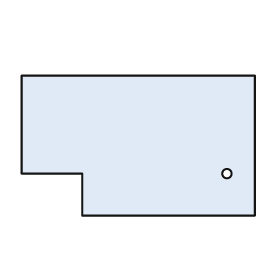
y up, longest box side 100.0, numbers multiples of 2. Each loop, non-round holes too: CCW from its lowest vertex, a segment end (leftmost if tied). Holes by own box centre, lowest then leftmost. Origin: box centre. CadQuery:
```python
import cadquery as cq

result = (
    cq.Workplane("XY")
    .moveTo(-24.0, -30.0)
    .lineTo(50.0, -30.0)
    .lineTo(50.0, 30.0)
    .lineTo(-50.0, 30.0)
    .lineTo(-50.0, -12.0)
    .lineTo(-24.0, -12.0)
    .close()
    .moveTo(38.0, -12.0)
    .circle(2.0)
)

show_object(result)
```